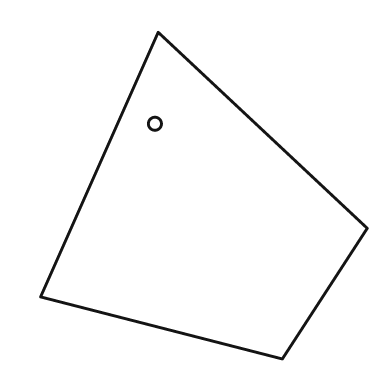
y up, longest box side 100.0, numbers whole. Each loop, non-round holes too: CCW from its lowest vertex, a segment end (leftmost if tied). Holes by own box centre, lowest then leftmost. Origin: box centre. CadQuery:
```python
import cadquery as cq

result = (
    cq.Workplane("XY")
    .moveTo(24.0, -50.0)
    .lineTo(50.0, -10.0)
    .lineTo(-14.0, 50.0)
    .lineTo(-50.0, -31.0)
    .close()
    .moveTo(-15.0, 22.0)
    .circle(2.0)
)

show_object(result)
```